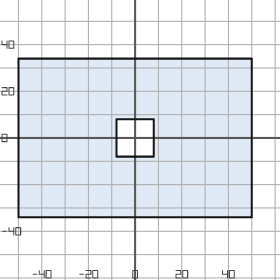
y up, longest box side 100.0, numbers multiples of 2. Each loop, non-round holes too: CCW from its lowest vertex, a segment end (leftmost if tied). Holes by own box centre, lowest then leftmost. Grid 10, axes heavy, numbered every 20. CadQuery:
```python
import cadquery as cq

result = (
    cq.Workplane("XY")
    .moveTo(-50.0, -34.0)
    .lineTo(50.0, -34.0)
    .lineTo(50.0, 34.0)
    .lineTo(-50.0, 34.0)
    .close()
    .moveTo(-8.0, -8.0)
    .lineTo(8.0, -8.0)
    .lineTo(8.0, 8.0)
    .lineTo(-8.0, 8.0)
    .close()
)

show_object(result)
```